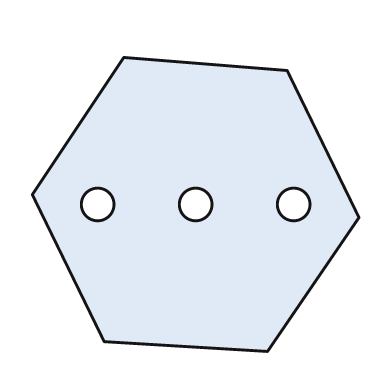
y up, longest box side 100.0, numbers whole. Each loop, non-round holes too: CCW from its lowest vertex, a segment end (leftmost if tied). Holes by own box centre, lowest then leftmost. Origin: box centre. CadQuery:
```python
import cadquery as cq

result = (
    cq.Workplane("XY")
    .moveTo(22.0, -45.0)
    .lineTo(50.0, -4.0)
    .lineTo(28.0, 41.0)
    .lineTo(-22.0, 45.0)
    .lineTo(-50.0, 3.0)
    .lineTo(-28.0, -42.0)
    .close()
    .moveTo(-30.0, 0.0)
    .circle(5.0)
    .moveTo(0.0, 0.0)
    .circle(5.0)
    .moveTo(30.0, 0.0)
    .circle(5.0)
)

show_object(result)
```